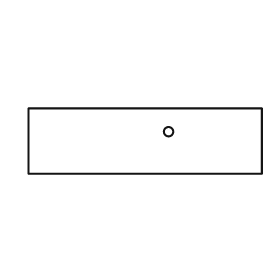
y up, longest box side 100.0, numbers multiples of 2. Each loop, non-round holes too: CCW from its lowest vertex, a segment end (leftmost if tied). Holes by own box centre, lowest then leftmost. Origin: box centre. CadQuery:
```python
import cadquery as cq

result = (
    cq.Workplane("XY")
    .moveTo(-50.0, -14.0)
    .lineTo(50.0, -14.0)
    .lineTo(50.0, 14.0)
    .lineTo(-50.0, 14.0)
    .close()
    .moveTo(10.0, 4.0)
    .circle(2.0)
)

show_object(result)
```